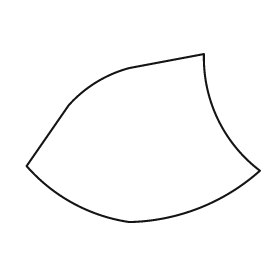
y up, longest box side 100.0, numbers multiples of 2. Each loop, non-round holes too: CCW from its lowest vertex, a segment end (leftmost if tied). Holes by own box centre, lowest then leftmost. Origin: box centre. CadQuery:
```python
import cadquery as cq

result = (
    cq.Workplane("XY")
    .moveTo(-6.0, -36.0)
    .threePointArc((24.0, -30.0), (50.0, -14.0))
    .threePointArc((32.0, 8.0), (26.0, 36.0))
    .lineTo(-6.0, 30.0)
    .threePointArc((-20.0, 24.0), (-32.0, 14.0))
    .lineTo(-50.0, -12.0)
    .threePointArc((-30.0, -28.0), (-6.0, -36.0))
    .close()
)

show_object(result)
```